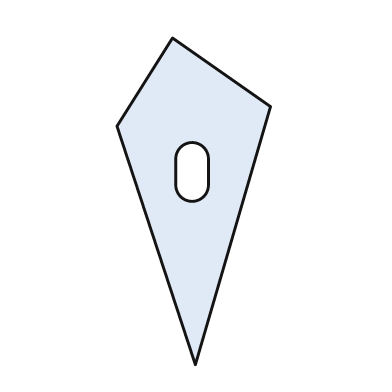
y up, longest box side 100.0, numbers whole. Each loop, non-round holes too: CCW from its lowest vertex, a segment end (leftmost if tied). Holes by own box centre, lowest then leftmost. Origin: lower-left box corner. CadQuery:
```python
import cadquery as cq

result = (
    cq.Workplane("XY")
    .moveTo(24.0, 0.0)
    .lineTo(47.0, 79.0)
    .lineTo(17.0, 100.0)
    .lineTo(0.0, 73.0)
    .close()
    .moveTo(18.0, 55.0)
    .threePointArc((23.0, 50.0), (28.0, 55.0))
    .lineTo(28.0, 63.0)
    .threePointArc((23.0, 68.0), (18.0, 63.0))
    .close()
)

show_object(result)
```